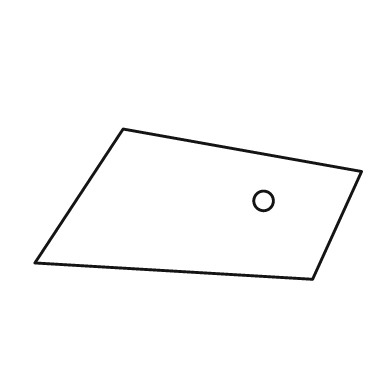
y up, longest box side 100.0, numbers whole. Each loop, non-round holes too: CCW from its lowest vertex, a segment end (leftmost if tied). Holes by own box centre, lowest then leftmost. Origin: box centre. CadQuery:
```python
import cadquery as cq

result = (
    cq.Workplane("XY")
    .moveTo(35.0, -23.0)
    .lineTo(50.0, 10.0)
    .lineTo(-23.0, 23.0)
    .lineTo(-50.0, -18.0)
    .close()
    .moveTo(20.0, 1.0)
    .circle(3.0)
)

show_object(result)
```